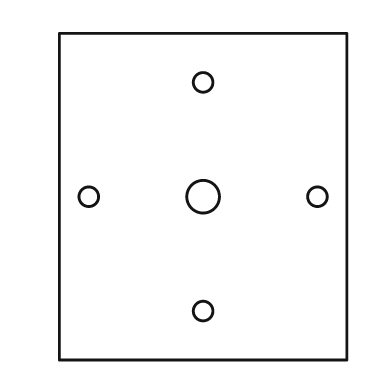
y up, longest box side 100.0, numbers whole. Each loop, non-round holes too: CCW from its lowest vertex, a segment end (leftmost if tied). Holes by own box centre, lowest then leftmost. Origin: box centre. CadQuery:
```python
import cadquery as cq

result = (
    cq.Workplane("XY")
    .moveTo(-44.0, -50.0)
    .lineTo(44.0, -50.0)
    .lineTo(44.0, 50.0)
    .lineTo(-44.0, 50.0)
    .close()
    .moveTo(0.0, -35.0)
    .circle(3.0)
    .moveTo(-35.0, 0.0)
    .circle(3.0)
    .moveTo(0.0, 0.0)
    .circle(5.0)
    .moveTo(35.0, 0.0)
    .circle(3.0)
    .moveTo(0.0, 35.0)
    .circle(3.0)
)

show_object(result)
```